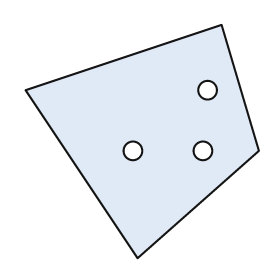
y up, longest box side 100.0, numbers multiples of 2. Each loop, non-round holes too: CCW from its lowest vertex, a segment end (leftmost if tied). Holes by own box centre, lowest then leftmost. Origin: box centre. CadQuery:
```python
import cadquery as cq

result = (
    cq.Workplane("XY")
    .moveTo(-2.0, -50.0)
    .lineTo(50.0, -4.0)
    .lineTo(34.0, 50.0)
    .lineTo(-50.0, 22.0)
    .close()
    .moveTo(-4.0, -4.0)
    .circle(4.0)
    .moveTo(26.0, -4.0)
    .circle(4.0)
    .moveTo(28.0, 22.0)
    .circle(4.0)
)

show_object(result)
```